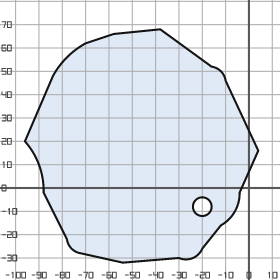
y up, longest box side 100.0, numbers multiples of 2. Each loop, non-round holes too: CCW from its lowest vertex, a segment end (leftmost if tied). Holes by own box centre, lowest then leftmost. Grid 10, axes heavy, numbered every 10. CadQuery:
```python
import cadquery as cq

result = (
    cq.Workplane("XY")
    .moveTo(-54.0, -32.0)
    .lineTo(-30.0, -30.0)
    .threePointArc((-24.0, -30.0), (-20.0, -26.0))
    .lineTo(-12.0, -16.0)
    .threePointArc((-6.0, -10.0), (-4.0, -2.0))
    .lineTo(4.0, 16.0)
    .lineTo(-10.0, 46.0)
    .threePointArc((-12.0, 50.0), (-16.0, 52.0))
    .lineTo(-38.0, 68.0)
    .lineTo(-58.0, 66.0)
    .lineTo(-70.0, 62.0)
    .threePointArc((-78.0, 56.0), (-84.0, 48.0))
    .lineTo(-96.0, 20.0)
    .threePointArc((-90.0, 10.0), (-88.0, -2.0))
    .lineTo(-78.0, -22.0)
    .threePointArc((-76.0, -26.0), (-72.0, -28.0))
    .close()
    .moveTo(-20.0, -8.0)
    .circle(4.0)
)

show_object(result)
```